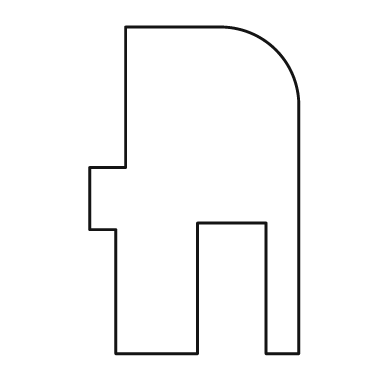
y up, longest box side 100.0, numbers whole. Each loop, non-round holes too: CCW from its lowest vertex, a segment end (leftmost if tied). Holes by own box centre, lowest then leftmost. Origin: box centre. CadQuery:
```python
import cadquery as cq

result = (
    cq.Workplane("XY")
    .moveTo(-24.0, -50.0)
    .lineTo(1.0, -50.0)
    .lineTo(1.0, -10.0)
    .lineTo(22.0, -10.0)
    .lineTo(22.0, -50.0)
    .lineTo(32.0, -50.0)
    .lineTo(32.0, 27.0)
    .threePointArc((25.0, 43.0), (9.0, 50.0))
    .lineTo(-21.0, 50.0)
    .lineTo(-21.0, 7.0)
    .lineTo(-32.0, 7.0)
    .lineTo(-32.0, -12.0)
    .lineTo(-24.0, -12.0)
    .close()
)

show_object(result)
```